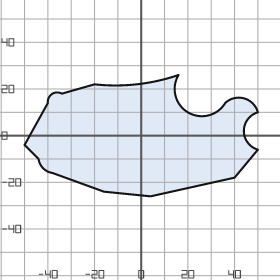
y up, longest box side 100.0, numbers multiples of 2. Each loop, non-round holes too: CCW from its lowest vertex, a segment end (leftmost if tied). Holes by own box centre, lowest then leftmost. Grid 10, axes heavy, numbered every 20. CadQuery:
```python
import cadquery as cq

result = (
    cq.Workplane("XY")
    .moveTo(4.0, -26.0)
    .lineTo(40.0, -18.0)
    .lineTo(50.0, -6.0)
    .threePointArc((44.0, 2.0), (50.0, 10.0))
    .threePointArc((44.0, 16.0), (36.0, 14.0))
    .threePointArc((20.0, 10.0), (16.0, 26.0))
    .threePointArc((-2.0, 22.0), (-20.0, 22.0))
    .lineTo(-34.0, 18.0)
    .threePointArc((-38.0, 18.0), (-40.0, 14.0))
    .lineTo(-50.0, -4.0)
    .lineTo(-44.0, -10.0)
    .threePointArc((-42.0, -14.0), (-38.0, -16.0))
    .lineTo(-16.0, -24.0)
    .close()
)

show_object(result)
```